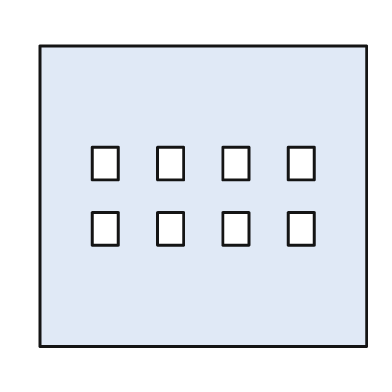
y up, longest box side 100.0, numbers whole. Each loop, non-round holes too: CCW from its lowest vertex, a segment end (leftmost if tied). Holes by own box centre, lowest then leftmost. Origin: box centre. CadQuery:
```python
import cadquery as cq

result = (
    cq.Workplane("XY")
    .moveTo(-50.0, -46.0)
    .lineTo(50.0, -46.0)
    .lineTo(50.0, 46.0)
    .lineTo(-50.0, 46.0)
    .close()
    .moveTo(-34.0, -15.0)
    .lineTo(-26.0, -15.0)
    .lineTo(-26.0, -5.0)
    .lineTo(-34.0, -5.0)
    .close()
    .moveTo(-14.0, -15.0)
    .lineTo(-6.0, -15.0)
    .lineTo(-6.0, -5.0)
    .lineTo(-14.0, -5.0)
    .close()
    .moveTo(6.0, -15.0)
    .lineTo(14.0, -15.0)
    .lineTo(14.0, -5.0)
    .lineTo(6.0, -5.0)
    .close()
    .moveTo(26.0, -15.0)
    .lineTo(34.0, -15.0)
    .lineTo(34.0, -5.0)
    .lineTo(26.0, -5.0)
    .close()
    .moveTo(-34.0, 5.0)
    .lineTo(-26.0, 5.0)
    .lineTo(-26.0, 15.0)
    .lineTo(-34.0, 15.0)
    .close()
    .moveTo(-14.0, 5.0)
    .lineTo(-6.0, 5.0)
    .lineTo(-6.0, 15.0)
    .lineTo(-14.0, 15.0)
    .close()
    .moveTo(6.0, 5.0)
    .lineTo(14.0, 5.0)
    .lineTo(14.0, 15.0)
    .lineTo(6.0, 15.0)
    .close()
    .moveTo(26.0, 5.0)
    .lineTo(34.0, 5.0)
    .lineTo(34.0, 15.0)
    .lineTo(26.0, 15.0)
    .close()
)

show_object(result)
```